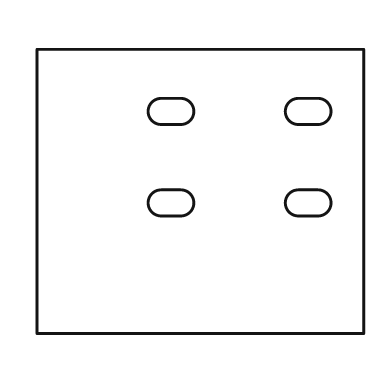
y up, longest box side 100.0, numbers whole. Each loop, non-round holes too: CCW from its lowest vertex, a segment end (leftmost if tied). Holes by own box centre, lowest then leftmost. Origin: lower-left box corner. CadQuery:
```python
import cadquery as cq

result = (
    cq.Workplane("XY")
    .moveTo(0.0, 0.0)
    .lineTo(100.0, 0.0)
    .lineTo(100.0, 87.0)
    .lineTo(0.0, 87.0)
    .close()
    .moveTo(38.0, 36.0)
    .lineTo(44.0, 36.0)
    .threePointArc((48.0, 40.0), (44.0, 44.0))
    .lineTo(38.0, 44.0)
    .threePointArc((34.0, 40.0), (38.0, 36.0))
    .close()
    .moveTo(80.0, 36.0)
    .lineTo(86.0, 36.0)
    .threePointArc((90.0, 40.0), (86.0, 44.0))
    .lineTo(80.0, 44.0)
    .threePointArc((76.0, 40.0), (80.0, 36.0))
    .close()
    .moveTo(38.0, 64.0)
    .lineTo(44.0, 64.0)
    .threePointArc((48.0, 68.0), (44.0, 72.0))
    .lineTo(38.0, 72.0)
    .threePointArc((34.0, 68.0), (38.0, 64.0))
    .close()
    .moveTo(80.0, 64.0)
    .lineTo(86.0, 64.0)
    .threePointArc((90.0, 68.0), (86.0, 72.0))
    .lineTo(80.0, 72.0)
    .threePointArc((76.0, 68.0), (80.0, 64.0))
    .close()
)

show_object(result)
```